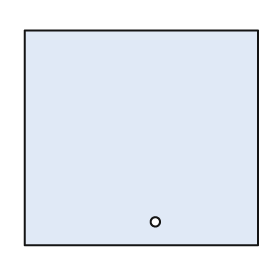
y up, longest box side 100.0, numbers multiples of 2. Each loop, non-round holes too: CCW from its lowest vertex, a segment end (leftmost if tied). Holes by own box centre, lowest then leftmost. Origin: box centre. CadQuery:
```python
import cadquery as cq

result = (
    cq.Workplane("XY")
    .moveTo(-50.0, -46.0)
    .lineTo(50.0, -46.0)
    .lineTo(50.0, 46.0)
    .lineTo(-50.0, 46.0)
    .close()
    .moveTo(6.0, -36.0)
    .circle(2.0)
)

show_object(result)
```